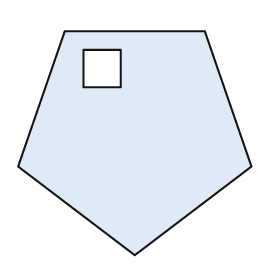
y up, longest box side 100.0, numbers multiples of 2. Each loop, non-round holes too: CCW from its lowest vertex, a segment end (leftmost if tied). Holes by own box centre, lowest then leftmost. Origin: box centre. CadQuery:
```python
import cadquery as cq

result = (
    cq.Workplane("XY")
    .moveTo(0.0, -48.0)
    .lineTo(50.0, -10.0)
    .lineTo(30.0, 48.0)
    .lineTo(-30.0, 48.0)
    .lineTo(-50.0, -10.0)
    .close()
    .moveTo(-22.0, 24.0)
    .lineTo(-6.0, 24.0)
    .lineTo(-6.0, 40.0)
    .lineTo(-22.0, 40.0)
    .close()
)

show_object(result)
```